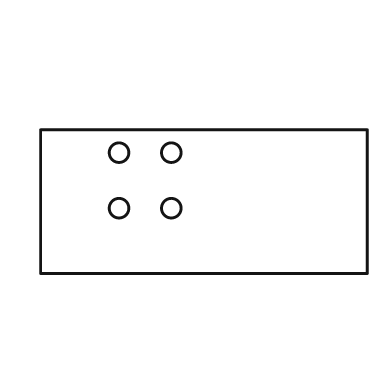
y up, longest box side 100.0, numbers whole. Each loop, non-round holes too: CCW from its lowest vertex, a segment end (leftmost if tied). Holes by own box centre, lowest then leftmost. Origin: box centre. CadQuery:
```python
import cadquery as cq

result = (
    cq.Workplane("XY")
    .moveTo(-50.0, -22.0)
    .lineTo(50.0, -22.0)
    .lineTo(50.0, 22.0)
    .lineTo(-50.0, 22.0)
    .close()
    .moveTo(-26.0, -2.0)
    .circle(3.0)
    .moveTo(-10.0, -2.0)
    .circle(3.0)
    .moveTo(-26.0, 15.0)
    .circle(3.0)
    .moveTo(-10.0, 15.0)
    .circle(3.0)
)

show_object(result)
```